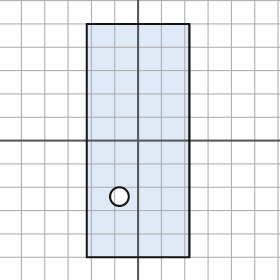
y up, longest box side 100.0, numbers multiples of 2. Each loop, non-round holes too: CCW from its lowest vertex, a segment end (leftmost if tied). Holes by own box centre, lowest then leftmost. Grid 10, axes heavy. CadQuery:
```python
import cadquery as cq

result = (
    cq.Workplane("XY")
    .moveTo(-22.0, -50.0)
    .lineTo(22.0, -50.0)
    .lineTo(22.0, 50.0)
    .lineTo(-22.0, 50.0)
    .close()
    .moveTo(-8.0, -24.0)
    .circle(4.0)
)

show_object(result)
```